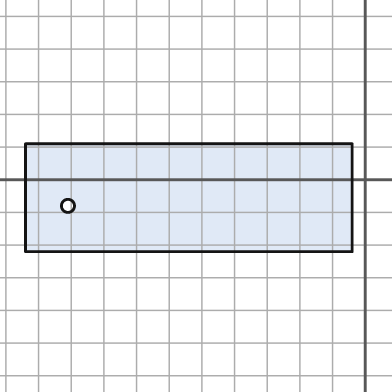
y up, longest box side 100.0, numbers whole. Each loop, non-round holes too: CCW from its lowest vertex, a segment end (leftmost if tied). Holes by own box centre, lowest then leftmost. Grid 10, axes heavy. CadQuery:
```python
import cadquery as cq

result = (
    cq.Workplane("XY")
    .moveTo(-104.0, -22.0)
    .lineTo(-4.0, -22.0)
    .lineTo(-4.0, 11.0)
    .lineTo(-104.0, 11.0)
    .close()
    .moveTo(-91.0, -8.0)
    .circle(2.0)
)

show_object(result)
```